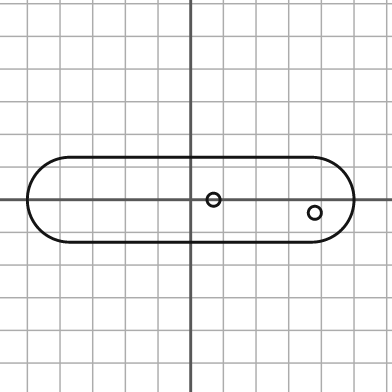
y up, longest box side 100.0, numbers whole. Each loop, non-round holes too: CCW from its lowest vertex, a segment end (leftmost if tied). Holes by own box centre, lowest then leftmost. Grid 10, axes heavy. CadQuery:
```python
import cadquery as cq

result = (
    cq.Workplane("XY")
    .moveTo(-37.0, -13.0)
    .lineTo(37.0, -13.0)
    .threePointArc((50.0, 0.0), (37.0, 13.0))
    .lineTo(-37.0, 13.0)
    .threePointArc((-50.0, 0.0), (-37.0, -13.0))
    .close()
    .moveTo(38.0, -4.0)
    .circle(2.0)
    .moveTo(7.0, 0.0)
    .circle(2.0)
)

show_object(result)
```